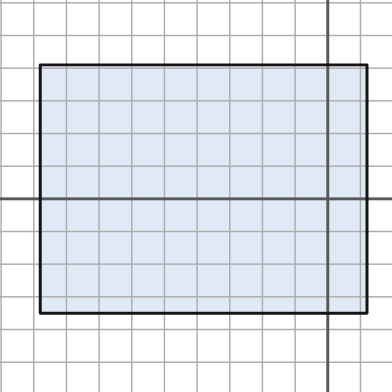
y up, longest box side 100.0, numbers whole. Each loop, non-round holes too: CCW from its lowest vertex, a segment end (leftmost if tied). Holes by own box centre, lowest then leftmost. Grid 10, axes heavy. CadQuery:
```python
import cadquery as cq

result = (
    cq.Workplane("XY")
    .moveTo(-88.0, -35.0)
    .lineTo(12.0, -35.0)
    .lineTo(12.0, 41.0)
    .lineTo(-88.0, 41.0)
    .close()
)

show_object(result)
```